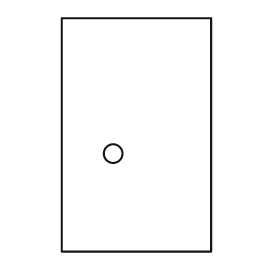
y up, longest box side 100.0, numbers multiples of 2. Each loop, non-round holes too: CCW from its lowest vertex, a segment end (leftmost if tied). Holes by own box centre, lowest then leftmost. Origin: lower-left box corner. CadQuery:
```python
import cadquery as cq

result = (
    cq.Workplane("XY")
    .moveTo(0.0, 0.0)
    .lineTo(64.0, 0.0)
    .lineTo(64.0, 100.0)
    .lineTo(0.0, 100.0)
    .close()
    .moveTo(22.0, 42.0)
    .circle(4.0)
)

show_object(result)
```